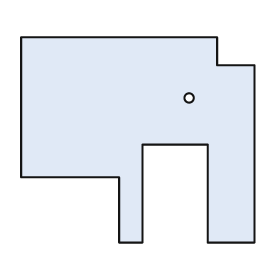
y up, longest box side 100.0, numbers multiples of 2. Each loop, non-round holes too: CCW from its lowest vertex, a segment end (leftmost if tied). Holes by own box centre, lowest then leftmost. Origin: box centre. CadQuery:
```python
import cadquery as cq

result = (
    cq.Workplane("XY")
    .moveTo(-8.0, -44.0)
    .lineTo(2.0, -44.0)
    .lineTo(2.0, -2.0)
    .lineTo(30.0, -2.0)
    .lineTo(30.0, -44.0)
    .lineTo(50.0, -44.0)
    .lineTo(50.0, 32.0)
    .lineTo(34.0, 32.0)
    .lineTo(34.0, 44.0)
    .lineTo(-50.0, 44.0)
    .lineTo(-50.0, -16.0)
    .lineTo(-8.0, -16.0)
    .close()
    .moveTo(22.0, 18.0)
    .circle(2.0)
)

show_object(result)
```